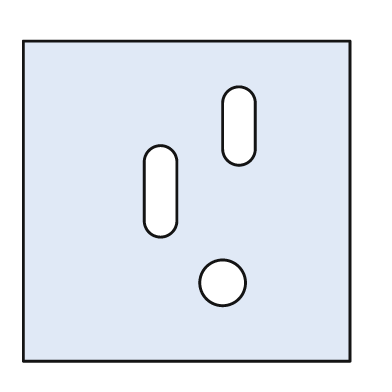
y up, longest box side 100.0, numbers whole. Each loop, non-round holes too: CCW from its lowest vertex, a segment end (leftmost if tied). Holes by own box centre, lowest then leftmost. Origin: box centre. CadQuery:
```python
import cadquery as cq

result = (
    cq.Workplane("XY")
    .moveTo(-50.0, -49.0)
    .lineTo(50.0, -49.0)
    .lineTo(50.0, 49.0)
    .lineTo(-50.0, 49.0)
    .close()
    .moveTo(11.0, -25.0)
    .circle(7.0)
    .moveTo(-13.0, -6.0)
    .threePointArc((-8.0, -11.0), (-3.0, -6.0))
    .lineTo(-3.0, 12.0)
    .threePointArc((-8.0, 17.0), (-13.0, 12.0))
    .close()
    .moveTo(11.0, 16.0)
    .threePointArc((16.0, 11.0), (21.0, 16.0))
    .lineTo(21.0, 30.0)
    .threePointArc((16.0, 35.0), (11.0, 30.0))
    .close()
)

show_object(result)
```